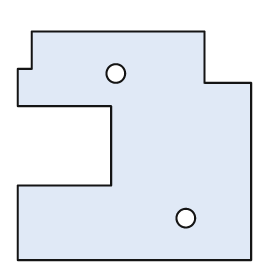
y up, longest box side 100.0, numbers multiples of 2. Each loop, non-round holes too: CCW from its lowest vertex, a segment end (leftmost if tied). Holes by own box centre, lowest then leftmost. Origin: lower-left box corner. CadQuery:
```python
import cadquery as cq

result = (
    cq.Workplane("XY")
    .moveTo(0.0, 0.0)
    .lineTo(100.0, 0.0)
    .lineTo(100.0, 76.0)
    .lineTo(80.0, 76.0)
    .lineTo(80.0, 98.0)
    .lineTo(6.0, 98.0)
    .lineTo(6.0, 82.0)
    .lineTo(0.0, 82.0)
    .lineTo(0.0, 66.0)
    .lineTo(40.0, 66.0)
    .lineTo(40.0, 32.0)
    .lineTo(0.0, 32.0)
    .close()
    .moveTo(72.0, 18.0)
    .circle(4.0)
    .moveTo(42.0, 80.0)
    .circle(4.0)
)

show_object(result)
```